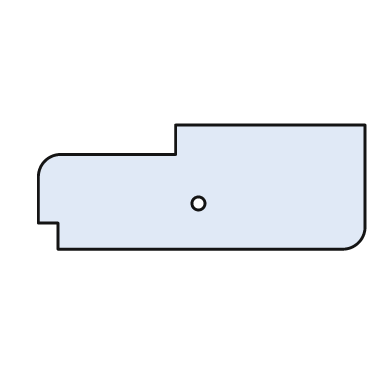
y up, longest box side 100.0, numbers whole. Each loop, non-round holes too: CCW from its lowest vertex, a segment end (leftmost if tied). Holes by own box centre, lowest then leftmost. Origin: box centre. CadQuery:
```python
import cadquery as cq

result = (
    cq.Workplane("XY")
    .moveTo(-44.0, -19.0)
    .lineTo(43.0, -19.0)
    .threePointArc((48.0, -17.0), (50.0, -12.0))
    .lineTo(50.0, 19.0)
    .lineTo(-8.0, 19.0)
    .lineTo(-8.0, 10.0)
    .lineTo(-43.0, 10.0)
    .threePointArc((-48.0, 8.0), (-50.0, 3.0))
    .lineTo(-50.0, -11.0)
    .lineTo(-44.0, -11.0)
    .close()
    .moveTo(-1.0, -5.0)
    .circle(2.0)
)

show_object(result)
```